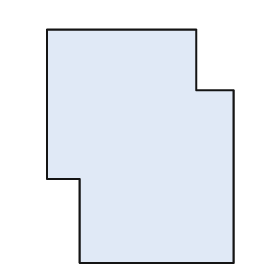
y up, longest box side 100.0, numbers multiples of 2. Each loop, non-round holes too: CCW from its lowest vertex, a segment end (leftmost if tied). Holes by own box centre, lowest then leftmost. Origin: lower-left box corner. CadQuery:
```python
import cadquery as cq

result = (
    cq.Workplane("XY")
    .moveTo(14.0, 0.0)
    .lineTo(80.0, 0.0)
    .lineTo(80.0, 74.0)
    .lineTo(64.0, 74.0)
    .lineTo(64.0, 100.0)
    .lineTo(0.0, 100.0)
    .lineTo(0.0, 36.0)
    .lineTo(14.0, 36.0)
    .close()
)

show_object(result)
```